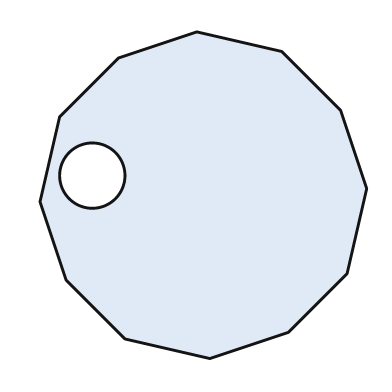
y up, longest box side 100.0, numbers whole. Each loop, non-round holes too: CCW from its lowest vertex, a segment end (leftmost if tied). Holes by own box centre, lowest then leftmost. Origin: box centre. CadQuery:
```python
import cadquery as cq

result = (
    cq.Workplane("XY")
    .moveTo(2.0, -50.0)
    .lineTo(26.0, -42.0)
    .lineTo(44.0, -24.0)
    .lineTo(50.0, 2.0)
    .lineTo(42.0, 26.0)
    .lineTo(24.0, 44.0)
    .lineTo(-2.0, 50.0)
    .lineTo(-26.0, 42.0)
    .lineTo(-44.0, 24.0)
    .lineTo(-50.0, -2.0)
    .lineTo(-42.0, -26.0)
    .lineTo(-24.0, -44.0)
    .close()
    .moveTo(-34.0, 6.0)
    .circle(10.0)
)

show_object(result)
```